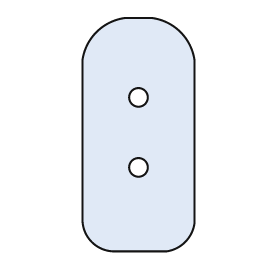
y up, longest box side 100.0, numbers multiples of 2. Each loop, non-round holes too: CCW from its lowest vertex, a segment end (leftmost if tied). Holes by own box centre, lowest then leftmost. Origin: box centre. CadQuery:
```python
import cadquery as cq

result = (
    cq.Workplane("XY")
    .moveTo(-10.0, -50.0)
    .lineTo(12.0, -50.0)
    .threePointArc((20.0, -46.0), (24.0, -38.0))
    .lineTo(24.0, 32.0)
    .threePointArc((18.0, 44.0), (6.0, 50.0))
    .lineTo(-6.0, 50.0)
    .threePointArc((-18.0, 44.0), (-24.0, 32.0))
    .lineTo(-24.0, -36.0)
    .threePointArc((-20.0, -46.0), (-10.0, -50.0))
    .close()
    .moveTo(0.0, -14.0)
    .circle(4.0)
    .moveTo(0.0, 16.0)
    .circle(4.0)
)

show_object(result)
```